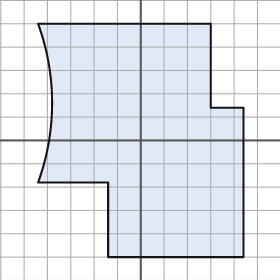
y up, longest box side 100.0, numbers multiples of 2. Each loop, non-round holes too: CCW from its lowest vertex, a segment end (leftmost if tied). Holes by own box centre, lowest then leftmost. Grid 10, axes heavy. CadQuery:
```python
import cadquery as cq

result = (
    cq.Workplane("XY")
    .moveTo(-14.0, -50.0)
    .lineTo(44.0, -50.0)
    .lineTo(44.0, 14.0)
    .lineTo(30.0, 14.0)
    .lineTo(30.0, 50.0)
    .lineTo(-44.0, 50.0)
    .threePointArc((-38.0, 16.0), (-44.0, -18.0))
    .lineTo(-14.0, -18.0)
    .close()
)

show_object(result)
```